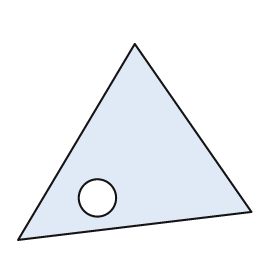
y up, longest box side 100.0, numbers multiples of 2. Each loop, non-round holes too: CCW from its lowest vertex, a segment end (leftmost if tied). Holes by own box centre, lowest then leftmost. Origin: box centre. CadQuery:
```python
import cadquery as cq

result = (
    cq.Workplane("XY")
    .moveTo(-50.0, -42.0)
    .lineTo(50.0, -30.0)
    .lineTo(0.0, 42.0)
    .close()
    .moveTo(-16.0, -24.0)
    .circle(8.0)
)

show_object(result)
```